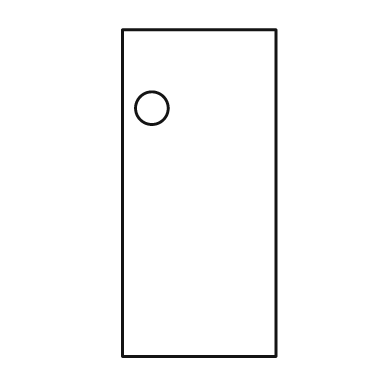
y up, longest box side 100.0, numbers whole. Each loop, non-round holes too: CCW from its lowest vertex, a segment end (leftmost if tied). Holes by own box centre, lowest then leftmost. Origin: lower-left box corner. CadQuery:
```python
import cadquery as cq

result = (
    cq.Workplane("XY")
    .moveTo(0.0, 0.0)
    .lineTo(47.0, 0.0)
    .lineTo(47.0, 100.0)
    .lineTo(0.0, 100.0)
    .close()
    .moveTo(9.0, 76.0)
    .circle(5.0)
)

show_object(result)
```